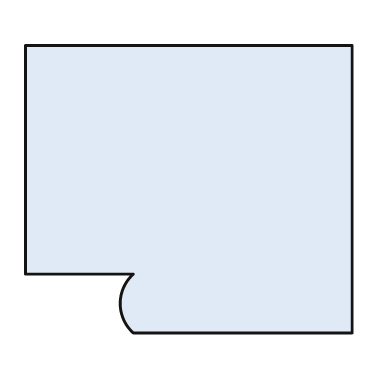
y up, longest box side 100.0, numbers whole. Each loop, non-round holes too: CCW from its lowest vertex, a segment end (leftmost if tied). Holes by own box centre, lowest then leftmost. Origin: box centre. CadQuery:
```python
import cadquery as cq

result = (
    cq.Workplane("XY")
    .moveTo(-17.0, -44.0)
    .lineTo(50.0, -44.0)
    .lineTo(50.0, 44.0)
    .lineTo(-50.0, 44.0)
    .lineTo(-50.0, -26.0)
    .lineTo(-17.0, -26.0)
    .threePointArc((-21.0, -35.0), (-17.0, -44.0))
    .close()
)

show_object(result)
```